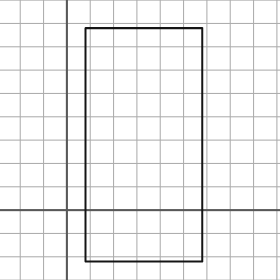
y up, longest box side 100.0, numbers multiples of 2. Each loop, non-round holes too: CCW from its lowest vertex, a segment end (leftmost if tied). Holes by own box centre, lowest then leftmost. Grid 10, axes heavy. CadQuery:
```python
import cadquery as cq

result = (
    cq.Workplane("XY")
    .moveTo(8.0, -22.0)
    .lineTo(58.0, -22.0)
    .lineTo(58.0, 78.0)
    .lineTo(8.0, 78.0)
    .close()
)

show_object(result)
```